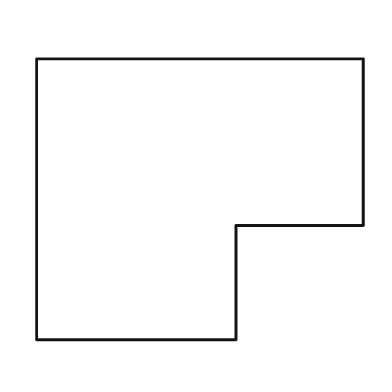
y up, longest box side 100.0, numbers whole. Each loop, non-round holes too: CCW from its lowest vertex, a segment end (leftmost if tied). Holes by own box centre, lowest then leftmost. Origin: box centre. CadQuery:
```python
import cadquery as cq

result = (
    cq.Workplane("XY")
    .moveTo(-50.0, -43.0)
    .lineTo(11.0, -43.0)
    .lineTo(11.0, -8.0)
    .lineTo(50.0, -8.0)
    .lineTo(50.0, 43.0)
    .lineTo(-50.0, 43.0)
    .close()
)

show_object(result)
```